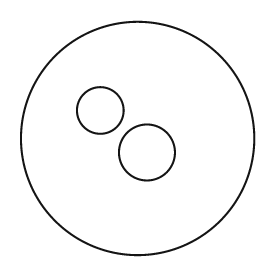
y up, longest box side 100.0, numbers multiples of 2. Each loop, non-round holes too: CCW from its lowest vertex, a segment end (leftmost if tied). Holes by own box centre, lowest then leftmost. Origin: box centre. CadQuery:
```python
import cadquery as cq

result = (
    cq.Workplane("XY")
    .moveTo(0.0, 0.0)
    .circle(50.0)
    .moveTo(4.0, -6.0)
    .circle(12.0)
    .moveTo(-16.0, 12.0)
    .circle(10.0)
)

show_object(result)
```